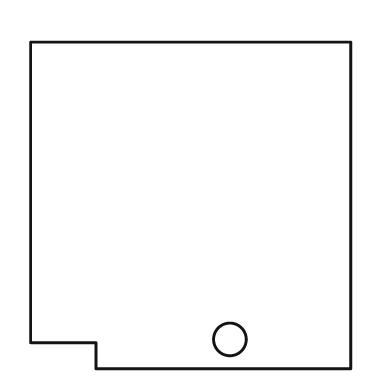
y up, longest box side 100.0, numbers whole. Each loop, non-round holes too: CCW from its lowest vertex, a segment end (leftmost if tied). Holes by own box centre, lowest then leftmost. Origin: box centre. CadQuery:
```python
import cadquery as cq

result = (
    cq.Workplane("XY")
    .moveTo(-29.0, -50.0)
    .lineTo(49.0, -50.0)
    .lineTo(49.0, 50.0)
    .lineTo(-49.0, 50.0)
    .lineTo(-49.0, -42.0)
    .lineTo(-29.0, -42.0)
    .close()
    .moveTo(12.0, -41.0)
    .circle(5.0)
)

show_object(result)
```